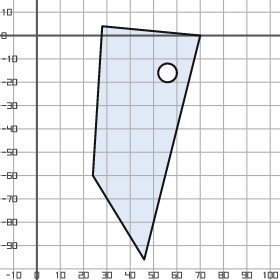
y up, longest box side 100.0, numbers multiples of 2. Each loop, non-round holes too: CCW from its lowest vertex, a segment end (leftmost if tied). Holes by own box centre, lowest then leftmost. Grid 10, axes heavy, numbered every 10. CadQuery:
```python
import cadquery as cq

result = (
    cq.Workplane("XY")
    .moveTo(46.0, -96.0)
    .lineTo(70.0, 0.0)
    .lineTo(28.0, 4.0)
    .lineTo(24.0, -60.0)
    .close()
    .moveTo(56.0, -16.0)
    .circle(4.0)
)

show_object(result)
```